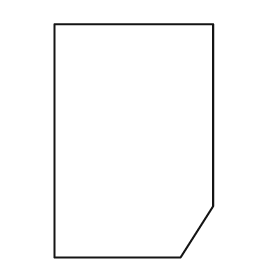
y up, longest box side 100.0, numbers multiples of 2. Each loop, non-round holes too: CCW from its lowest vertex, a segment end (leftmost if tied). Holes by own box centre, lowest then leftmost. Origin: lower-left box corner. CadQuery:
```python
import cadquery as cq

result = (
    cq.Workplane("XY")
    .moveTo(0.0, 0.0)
    .lineTo(54.0, 0.0)
    .lineTo(68.0, 22.0)
    .lineTo(68.0, 100.0)
    .lineTo(0.0, 100.0)
    .close()
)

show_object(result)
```